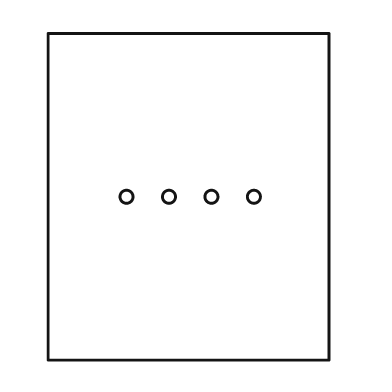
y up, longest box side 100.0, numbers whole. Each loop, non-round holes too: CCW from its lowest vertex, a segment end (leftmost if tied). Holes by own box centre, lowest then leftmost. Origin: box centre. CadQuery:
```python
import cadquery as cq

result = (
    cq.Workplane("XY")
    .moveTo(-43.0, -50.0)
    .lineTo(43.0, -50.0)
    .lineTo(43.0, 50.0)
    .lineTo(-43.0, 50.0)
    .close()
    .moveTo(-19.0, 0.0)
    .circle(2.0)
    .moveTo(-6.0, 0.0)
    .circle(2.0)
    .moveTo(7.0, 0.0)
    .circle(2.0)
    .moveTo(20.0, 0.0)
    .circle(2.0)
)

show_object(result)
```